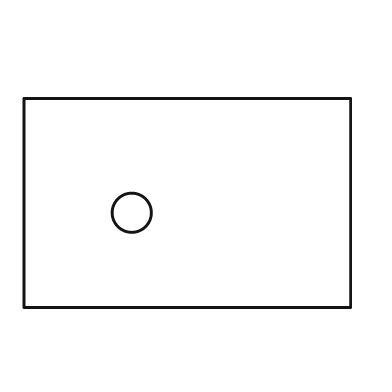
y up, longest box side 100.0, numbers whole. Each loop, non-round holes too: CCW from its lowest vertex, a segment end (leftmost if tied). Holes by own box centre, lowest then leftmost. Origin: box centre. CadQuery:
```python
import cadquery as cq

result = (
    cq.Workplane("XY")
    .moveTo(-50.0, -32.0)
    .lineTo(50.0, -32.0)
    .lineTo(50.0, 32.0)
    .lineTo(-50.0, 32.0)
    .close()
    .moveTo(-17.0, -3.0)
    .circle(6.0)
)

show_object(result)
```